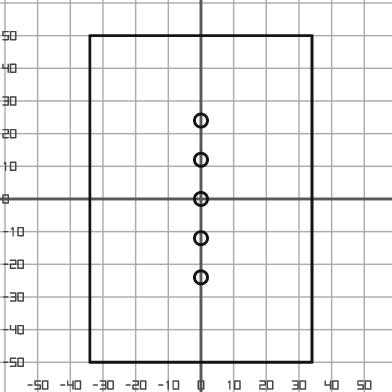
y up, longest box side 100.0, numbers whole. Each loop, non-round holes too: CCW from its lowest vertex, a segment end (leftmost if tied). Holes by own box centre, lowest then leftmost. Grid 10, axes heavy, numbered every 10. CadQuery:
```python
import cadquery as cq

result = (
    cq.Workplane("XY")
    .moveTo(-34.0, -50.0)
    .lineTo(34.0, -50.0)
    .lineTo(34.0, 50.0)
    .lineTo(-34.0, 50.0)
    .close()
    .moveTo(0.0, -24.0)
    .circle(2.0)
    .moveTo(0.0, -12.0)
    .circle(2.0)
    .moveTo(0.0, 0.0)
    .circle(2.0)
    .moveTo(0.0, 12.0)
    .circle(2.0)
    .moveTo(0.0, 24.0)
    .circle(2.0)
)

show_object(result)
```